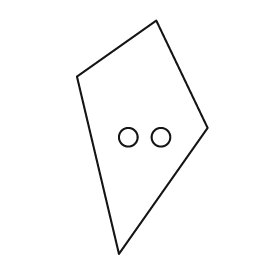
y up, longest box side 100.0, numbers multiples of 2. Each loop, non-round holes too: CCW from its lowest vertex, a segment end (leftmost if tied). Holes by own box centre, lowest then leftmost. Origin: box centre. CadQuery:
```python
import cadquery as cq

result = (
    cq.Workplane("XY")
    .moveTo(-10.0, -50.0)
    .lineTo(28.0, 4.0)
    .lineTo(6.0, 50.0)
    .lineTo(-28.0, 26.0)
    .close()
    .moveTo(-6.0, 0.0)
    .circle(4.0)
    .moveTo(8.0, 0.0)
    .circle(4.0)
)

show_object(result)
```